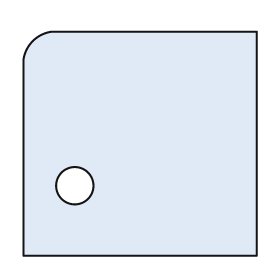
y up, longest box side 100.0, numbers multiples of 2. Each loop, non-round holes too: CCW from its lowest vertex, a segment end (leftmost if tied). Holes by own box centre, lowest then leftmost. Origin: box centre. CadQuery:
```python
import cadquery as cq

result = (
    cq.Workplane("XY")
    .moveTo(-50.0, -48.0)
    .lineTo(50.0, -48.0)
    .lineTo(50.0, 48.0)
    .lineTo(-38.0, 48.0)
    .threePointArc((-46.0, 44.0), (-50.0, 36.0))
    .close()
    .moveTo(-28.0, -18.0)
    .circle(8.0)
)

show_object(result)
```